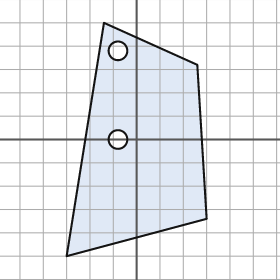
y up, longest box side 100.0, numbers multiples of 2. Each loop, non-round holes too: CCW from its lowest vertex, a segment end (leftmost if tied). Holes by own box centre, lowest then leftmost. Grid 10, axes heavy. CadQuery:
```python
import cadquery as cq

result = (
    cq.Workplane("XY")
    .moveTo(-30.0, -50.0)
    .lineTo(30.0, -34.0)
    .lineTo(26.0, 32.0)
    .lineTo(-14.0, 50.0)
    .close()
    .moveTo(-8.0, 0.0)
    .circle(4.0)
    .moveTo(-8.0, 38.0)
    .circle(4.0)
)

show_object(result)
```